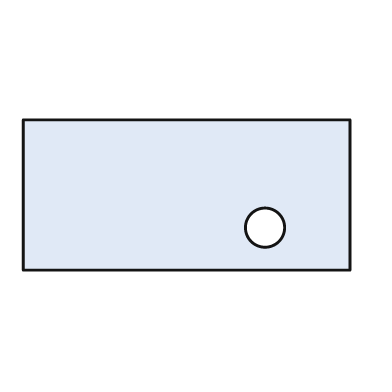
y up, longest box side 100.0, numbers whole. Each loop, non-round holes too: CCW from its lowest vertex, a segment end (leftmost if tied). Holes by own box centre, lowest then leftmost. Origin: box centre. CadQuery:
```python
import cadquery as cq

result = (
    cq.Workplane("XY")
    .moveTo(-50.0, -23.0)
    .lineTo(50.0, -23.0)
    .lineTo(50.0, 23.0)
    .lineTo(-50.0, 23.0)
    .close()
    .moveTo(24.0, -10.0)
    .circle(6.0)
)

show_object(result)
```